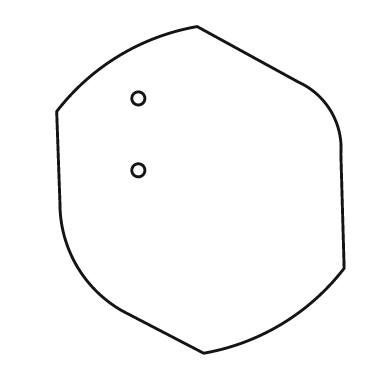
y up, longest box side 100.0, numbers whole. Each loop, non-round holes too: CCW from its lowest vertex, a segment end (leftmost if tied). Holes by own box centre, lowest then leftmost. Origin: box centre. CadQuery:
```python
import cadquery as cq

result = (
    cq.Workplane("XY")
    .moveTo(1.0, -50.0)
    .threePointArc((25.0, -41.0), (44.0, -24.0))
    .lineTo(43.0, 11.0)
    .threePointArc((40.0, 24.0), (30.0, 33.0))
    .lineTo(-1.0, 50.0)
    .threePointArc((-25.0, 41.0), (-44.0, 24.0))
    .lineTo(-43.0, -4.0)
    .threePointArc((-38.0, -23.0), (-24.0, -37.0))
    .close()
    .moveTo(-19.0, 6.0)
    .circle(2.0)
    .moveTo(-19.0, 28.0)
    .circle(2.0)
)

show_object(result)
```